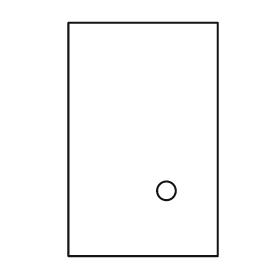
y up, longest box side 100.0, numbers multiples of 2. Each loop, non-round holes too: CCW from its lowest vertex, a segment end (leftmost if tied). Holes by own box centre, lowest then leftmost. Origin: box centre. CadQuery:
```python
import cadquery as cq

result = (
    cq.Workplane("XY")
    .moveTo(-32.0, -50.0)
    .lineTo(32.0, -50.0)
    .lineTo(32.0, 50.0)
    .lineTo(-32.0, 50.0)
    .close()
    .moveTo(10.0, -22.0)
    .circle(4.0)
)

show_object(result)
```